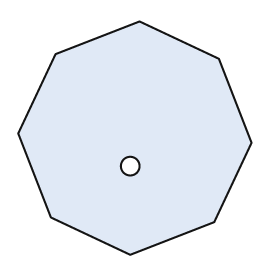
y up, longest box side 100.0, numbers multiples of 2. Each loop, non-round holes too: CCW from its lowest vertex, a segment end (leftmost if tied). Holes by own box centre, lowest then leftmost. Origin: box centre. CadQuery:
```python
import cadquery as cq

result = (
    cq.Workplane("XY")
    .moveTo(-2.0, -50.0)
    .lineTo(34.0, -36.0)
    .lineTo(50.0, -2.0)
    .lineTo(36.0, 34.0)
    .lineTo(2.0, 50.0)
    .lineTo(-34.0, 36.0)
    .lineTo(-50.0, 2.0)
    .lineTo(-36.0, -34.0)
    .close()
    .moveTo(-2.0, -12.0)
    .circle(4.0)
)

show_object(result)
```